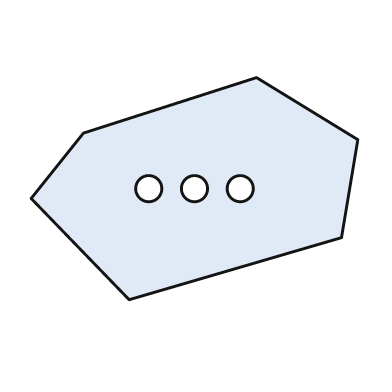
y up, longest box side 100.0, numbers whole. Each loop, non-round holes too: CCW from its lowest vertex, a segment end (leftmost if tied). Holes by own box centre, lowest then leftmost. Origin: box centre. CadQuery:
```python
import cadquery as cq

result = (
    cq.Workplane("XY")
    .moveTo(-20.0, -34.0)
    .lineTo(45.0, -15.0)
    .lineTo(50.0, 15.0)
    .lineTo(19.0, 34.0)
    .lineTo(-34.0, 17.0)
    .lineTo(-50.0, -3.0)
    .close()
    .moveTo(-14.0, 0.0)
    .circle(4.0)
    .moveTo(0.0, 0.0)
    .circle(4.0)
    .moveTo(14.0, 0.0)
    .circle(4.0)
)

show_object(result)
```